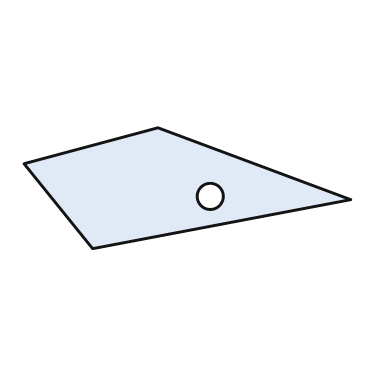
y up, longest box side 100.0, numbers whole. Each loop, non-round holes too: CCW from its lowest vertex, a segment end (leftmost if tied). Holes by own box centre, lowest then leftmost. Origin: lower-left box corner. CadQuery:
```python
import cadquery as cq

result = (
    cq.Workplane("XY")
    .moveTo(21.0, 0.0)
    .lineTo(100.0, 15.0)
    .lineTo(41.0, 37.0)
    .lineTo(0.0, 26.0)
    .close()
    .moveTo(57.0, 16.0)
    .circle(4.0)
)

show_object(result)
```